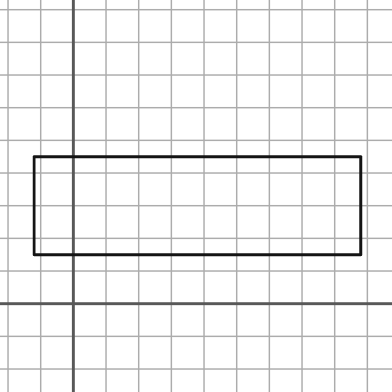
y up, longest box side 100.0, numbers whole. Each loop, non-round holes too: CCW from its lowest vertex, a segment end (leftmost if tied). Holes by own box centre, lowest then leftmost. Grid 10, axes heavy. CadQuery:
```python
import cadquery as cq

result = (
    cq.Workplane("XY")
    .moveTo(-12.0, 15.0)
    .lineTo(88.0, 15.0)
    .lineTo(88.0, 45.0)
    .lineTo(-12.0, 45.0)
    .close()
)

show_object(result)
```